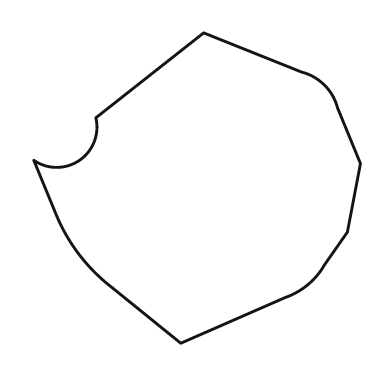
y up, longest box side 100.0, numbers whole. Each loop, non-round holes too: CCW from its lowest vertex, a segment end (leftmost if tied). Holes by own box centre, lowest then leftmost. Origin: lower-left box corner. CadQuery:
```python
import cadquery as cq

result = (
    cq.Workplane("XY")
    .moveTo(45.0, 0.0)
    .lineTo(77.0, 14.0)
    .threePointArc((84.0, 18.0), (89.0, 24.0))
    .lineTo(96.0, 34.0)
    .lineTo(100.0, 55.0)
    .lineTo(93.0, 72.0)
    .threePointArc((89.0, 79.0), (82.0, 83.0))
    .lineTo(52.0, 95.0)
    .lineTo(19.0, 69.0)
    .threePointArc((14.0, 56.0), (0.0, 56.0))
    .lineTo(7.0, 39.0)
    .threePointArc((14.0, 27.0), (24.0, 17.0))
    .close()
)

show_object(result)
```